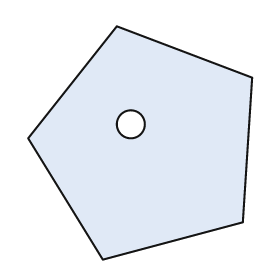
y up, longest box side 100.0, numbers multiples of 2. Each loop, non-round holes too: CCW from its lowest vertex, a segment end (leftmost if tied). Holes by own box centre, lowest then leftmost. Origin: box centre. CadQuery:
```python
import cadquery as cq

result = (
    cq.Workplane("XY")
    .moveTo(-16.0, -50.0)
    .lineTo(44.0, -34.0)
    .lineTo(48.0, 28.0)
    .lineTo(-10.0, 50.0)
    .lineTo(-48.0, 2.0)
    .close()
    .moveTo(-4.0, 8.0)
    .circle(6.0)
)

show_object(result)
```